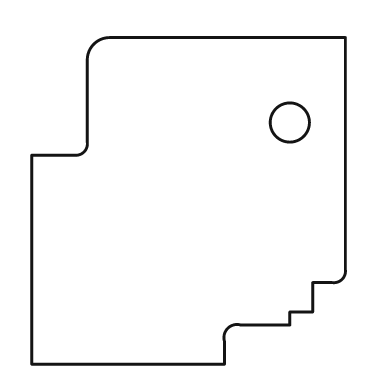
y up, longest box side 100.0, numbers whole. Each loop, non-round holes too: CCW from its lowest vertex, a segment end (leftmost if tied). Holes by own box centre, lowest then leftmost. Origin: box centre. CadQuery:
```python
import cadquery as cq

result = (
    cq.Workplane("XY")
    .moveTo(-48.0, -50.0)
    .lineTo(11.0, -50.0)
    .lineTo(11.0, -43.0)
    .threePointArc((12.0, -39.0), (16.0, -38.0))
    .lineTo(31.0, -38.0)
    .lineTo(31.0, -34.0)
    .lineTo(38.0, -34.0)
    .lineTo(38.0, -25.0)
    .lineTo(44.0, -25.0)
    .threePointArc((47.0, -24.0), (48.0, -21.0))
    .lineTo(48.0, 50.0)
    .lineTo(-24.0, 50.0)
    .threePointArc((-29.0, 48.0), (-31.0, 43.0))
    .lineTo(-31.0, 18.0)
    .threePointArc((-32.0, 15.0), (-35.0, 14.0))
    .lineTo(-48.0, 14.0)
    .close()
    .moveTo(31.0, 24.0)
    .circle(6.0)
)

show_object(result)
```